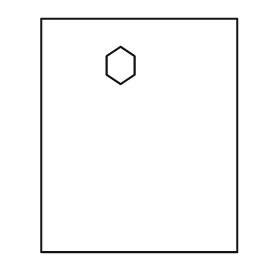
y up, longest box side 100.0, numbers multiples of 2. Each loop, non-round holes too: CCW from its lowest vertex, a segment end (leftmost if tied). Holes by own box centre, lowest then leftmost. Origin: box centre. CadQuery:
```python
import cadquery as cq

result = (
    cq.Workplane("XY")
    .moveTo(-42.0, -50.0)
    .lineTo(42.0, -50.0)
    .lineTo(42.0, 50.0)
    .lineTo(-42.0, 50.0)
    .close()
    .moveTo(-8.0, 22.0)
    .lineTo(-2.0, 26.0)
    .lineTo(-2.0, 34.0)
    .lineTo(-8.0, 38.0)
    .lineTo(-14.0, 34.0)
    .lineTo(-14.0, 26.0)
    .close()
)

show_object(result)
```